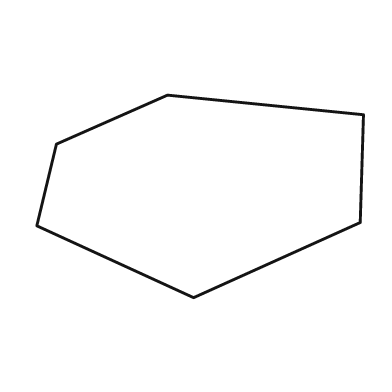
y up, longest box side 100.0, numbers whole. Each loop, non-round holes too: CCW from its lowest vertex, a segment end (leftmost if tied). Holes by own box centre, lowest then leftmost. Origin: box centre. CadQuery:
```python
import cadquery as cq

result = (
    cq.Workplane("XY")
    .moveTo(-2.0, -31.0)
    .lineTo(49.0, -8.0)
    .lineTo(50.0, 25.0)
    .lineTo(-10.0, 31.0)
    .lineTo(-44.0, 16.0)
    .lineTo(-50.0, -9.0)
    .close()
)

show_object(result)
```